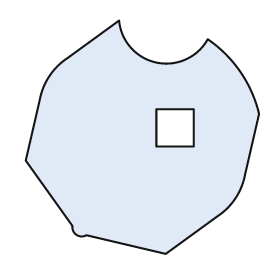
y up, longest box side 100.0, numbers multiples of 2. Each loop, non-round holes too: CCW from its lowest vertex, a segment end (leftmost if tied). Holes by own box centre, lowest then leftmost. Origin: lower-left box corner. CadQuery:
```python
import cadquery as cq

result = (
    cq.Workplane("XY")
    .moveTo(60.0, 0.0)
    .lineTo(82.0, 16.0)
    .threePointArc((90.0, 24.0), (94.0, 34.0))
    .lineTo(100.0, 60.0)
    .threePointArc((92.0, 78.0), (78.0, 92.0))
    .threePointArc((56.0, 82.0), (40.0, 100.0))
    .lineTo(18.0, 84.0)
    .threePointArc((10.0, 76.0), (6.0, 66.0))
    .lineTo(0.0, 40.0)
    .lineTo(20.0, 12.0)
    .threePointArc((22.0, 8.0), (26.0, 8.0))
    .close()
    .moveTo(56.0, 46.0)
    .lineTo(72.0, 46.0)
    .lineTo(72.0, 62.0)
    .lineTo(56.0, 62.0)
    .close()
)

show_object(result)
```